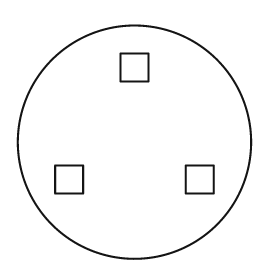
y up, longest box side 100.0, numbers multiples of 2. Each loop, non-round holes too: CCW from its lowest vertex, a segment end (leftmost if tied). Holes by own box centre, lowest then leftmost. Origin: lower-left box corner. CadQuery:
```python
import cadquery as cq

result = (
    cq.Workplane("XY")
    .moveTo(50.0, 50.0)
    .circle(50.0)
    .moveTo(16.0, 28.0)
    .lineTo(28.0, 28.0)
    .lineTo(28.0, 40.0)
    .lineTo(16.0, 40.0)
    .close()
    .moveTo(72.0, 28.0)
    .lineTo(84.0, 28.0)
    .lineTo(84.0, 40.0)
    .lineTo(72.0, 40.0)
    .close()
    .moveTo(44.0, 76.0)
    .lineTo(56.0, 76.0)
    .lineTo(56.0, 88.0)
    .lineTo(44.0, 88.0)
    .close()
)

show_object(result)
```